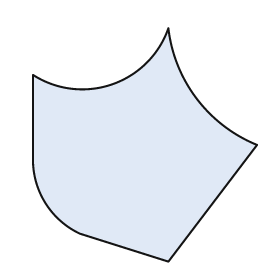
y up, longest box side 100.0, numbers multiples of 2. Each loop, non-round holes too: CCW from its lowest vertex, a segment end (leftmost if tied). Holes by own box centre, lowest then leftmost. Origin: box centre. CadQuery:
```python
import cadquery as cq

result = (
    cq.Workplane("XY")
    .moveTo(10.0, -50.0)
    .lineTo(48.0, 0.0)
    .threePointArc((22.0, 20.0), (10.0, 50.0))
    .threePointArc((-14.0, 26.0), (-48.0, 30.0))
    .lineTo(-48.0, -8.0)
    .threePointArc((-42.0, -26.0), (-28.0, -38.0))
    .close()
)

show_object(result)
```